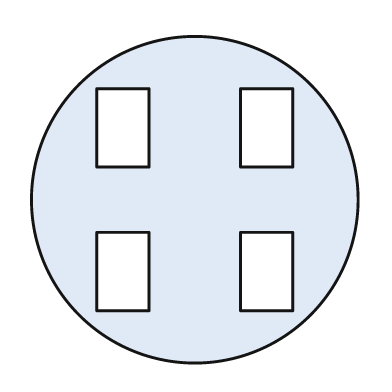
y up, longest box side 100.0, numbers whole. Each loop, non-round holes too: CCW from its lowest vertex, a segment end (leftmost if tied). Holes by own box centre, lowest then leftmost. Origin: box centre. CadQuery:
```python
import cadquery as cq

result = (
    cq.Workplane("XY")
    .moveTo(0.0, 0.0)
    .circle(50.0)
    .moveTo(-30.0, -34.0)
    .lineTo(-14.0, -34.0)
    .lineTo(-14.0, -10.0)
    .lineTo(-30.0, -10.0)
    .close()
    .moveTo(14.0, -34.0)
    .lineTo(30.0, -34.0)
    .lineTo(30.0, -10.0)
    .lineTo(14.0, -10.0)
    .close()
    .moveTo(-30.0, 10.0)
    .lineTo(-14.0, 10.0)
    .lineTo(-14.0, 34.0)
    .lineTo(-30.0, 34.0)
    .close()
    .moveTo(14.0, 10.0)
    .lineTo(30.0, 10.0)
    .lineTo(30.0, 34.0)
    .lineTo(14.0, 34.0)
    .close()
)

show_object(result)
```